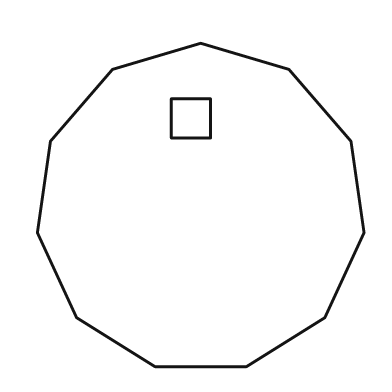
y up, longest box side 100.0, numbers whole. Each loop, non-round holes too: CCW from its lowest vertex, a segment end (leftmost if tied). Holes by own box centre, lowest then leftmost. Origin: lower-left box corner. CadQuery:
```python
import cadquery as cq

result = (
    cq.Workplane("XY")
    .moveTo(36.0, 0.0)
    .lineTo(64.0, 0.0)
    .lineTo(88.0, 15.0)
    .lineTo(100.0, 41.0)
    .lineTo(96.0, 69.0)
    .lineTo(77.0, 91.0)
    .lineTo(50.0, 99.0)
    .lineTo(23.0, 91.0)
    .lineTo(4.0, 69.0)
    .lineTo(0.0, 41.0)
    .lineTo(12.0, 15.0)
    .close()
    .moveTo(41.0, 70.0)
    .lineTo(53.0, 70.0)
    .lineTo(53.0, 82.0)
    .lineTo(41.0, 82.0)
    .close()
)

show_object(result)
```